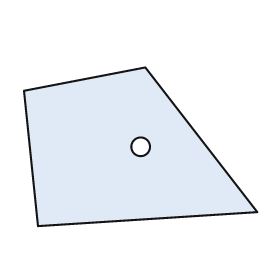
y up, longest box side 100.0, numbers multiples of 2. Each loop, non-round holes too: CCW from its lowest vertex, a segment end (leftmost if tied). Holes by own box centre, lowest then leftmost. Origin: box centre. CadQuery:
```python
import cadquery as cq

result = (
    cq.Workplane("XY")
    .moveTo(-44.0, -34.0)
    .lineTo(50.0, -28.0)
    .lineTo(2.0, 34.0)
    .lineTo(-50.0, 24.0)
    .close()
    .moveTo(0.0, 0.0)
    .circle(4.0)
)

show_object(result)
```